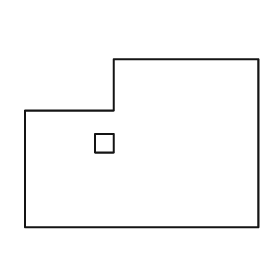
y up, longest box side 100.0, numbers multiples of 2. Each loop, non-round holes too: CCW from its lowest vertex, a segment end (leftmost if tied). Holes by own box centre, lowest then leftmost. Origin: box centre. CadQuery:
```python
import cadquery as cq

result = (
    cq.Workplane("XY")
    .moveTo(-50.0, -36.0)
    .lineTo(50.0, -36.0)
    .lineTo(50.0, 36.0)
    .lineTo(-12.0, 36.0)
    .lineTo(-12.0, 14.0)
    .lineTo(-50.0, 14.0)
    .close()
    .moveTo(-20.0, -4.0)
    .lineTo(-12.0, -4.0)
    .lineTo(-12.0, 4.0)
    .lineTo(-20.0, 4.0)
    .close()
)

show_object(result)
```